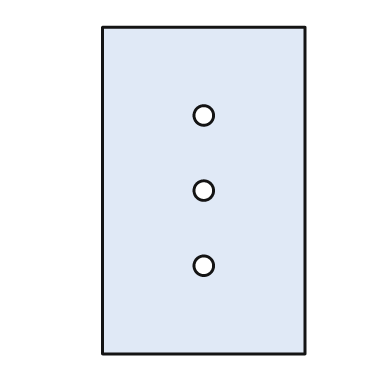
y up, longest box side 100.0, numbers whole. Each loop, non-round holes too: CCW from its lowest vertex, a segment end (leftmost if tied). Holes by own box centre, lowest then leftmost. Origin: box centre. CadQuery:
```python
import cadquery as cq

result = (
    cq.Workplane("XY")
    .moveTo(-31.0, -50.0)
    .lineTo(31.0, -50.0)
    .lineTo(31.0, 50.0)
    .lineTo(-31.0, 50.0)
    .close()
    .moveTo(0.0, -23.0)
    .circle(3.0)
    .moveTo(0.0, 0.0)
    .circle(3.0)
    .moveTo(0.0, 23.0)
    .circle(3.0)
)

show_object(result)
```